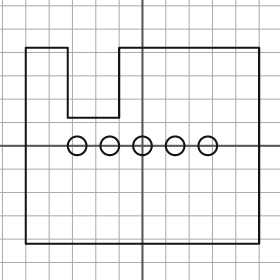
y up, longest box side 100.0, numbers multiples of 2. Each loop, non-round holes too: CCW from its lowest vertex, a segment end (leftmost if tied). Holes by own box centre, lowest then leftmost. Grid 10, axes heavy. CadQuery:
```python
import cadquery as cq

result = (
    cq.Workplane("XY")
    .moveTo(-50.0, -42.0)
    .lineTo(50.0, -42.0)
    .lineTo(50.0, 42.0)
    .lineTo(-10.0, 42.0)
    .lineTo(-10.0, 12.0)
    .lineTo(-32.0, 12.0)
    .lineTo(-32.0, 42.0)
    .lineTo(-50.0, 42.0)
    .close()
    .moveTo(-28.0, 0.0)
    .circle(4.0)
    .moveTo(-14.0, 0.0)
    .circle(4.0)
    .moveTo(0.0, 0.0)
    .circle(4.0)
    .moveTo(14.0, 0.0)
    .circle(4.0)
    .moveTo(28.0, 0.0)
    .circle(4.0)
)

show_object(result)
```